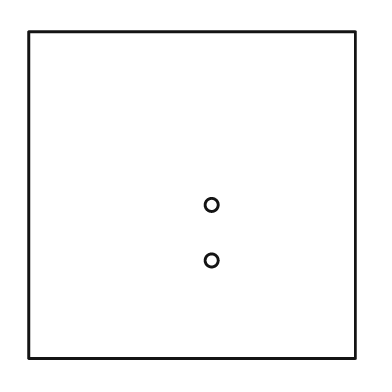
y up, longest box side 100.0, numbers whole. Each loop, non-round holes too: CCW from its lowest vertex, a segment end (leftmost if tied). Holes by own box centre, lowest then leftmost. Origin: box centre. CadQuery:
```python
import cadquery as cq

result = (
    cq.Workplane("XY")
    .moveTo(-50.0, -50.0)
    .lineTo(50.0, -50.0)
    .lineTo(50.0, 50.0)
    .lineTo(-50.0, 50.0)
    .close()
    .moveTo(6.0, -20.0)
    .circle(2.0)
    .moveTo(6.0, -3.0)
    .circle(2.0)
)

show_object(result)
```